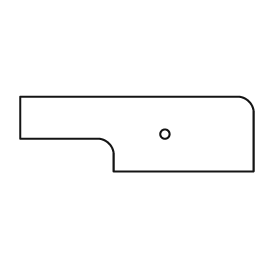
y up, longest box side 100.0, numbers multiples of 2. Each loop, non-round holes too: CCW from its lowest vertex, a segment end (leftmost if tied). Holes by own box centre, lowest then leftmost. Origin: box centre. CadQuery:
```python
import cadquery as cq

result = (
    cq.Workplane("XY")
    .moveTo(-10.0, -16.0)
    .lineTo(50.0, -16.0)
    .lineTo(50.0, 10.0)
    .threePointArc((48.0, 14.0), (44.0, 16.0))
    .lineTo(-50.0, 16.0)
    .lineTo(-50.0, -2.0)
    .lineTo(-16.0, -2.0)
    .threePointArc((-12.0, -4.0), (-10.0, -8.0))
    .close()
    .moveTo(12.0, 0.0)
    .circle(2.0)
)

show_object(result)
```